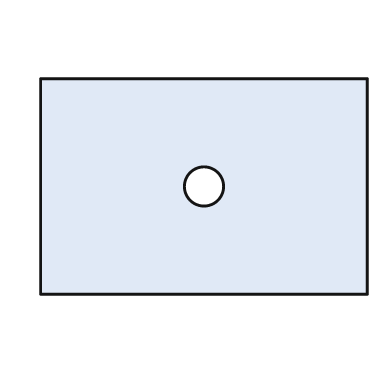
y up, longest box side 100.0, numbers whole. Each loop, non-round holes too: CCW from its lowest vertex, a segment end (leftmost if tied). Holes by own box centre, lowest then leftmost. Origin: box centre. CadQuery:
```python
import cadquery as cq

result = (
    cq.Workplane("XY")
    .moveTo(-50.0, -33.0)
    .lineTo(50.0, -33.0)
    .lineTo(50.0, 33.0)
    .lineTo(-50.0, 33.0)
    .close()
    .moveTo(0.0, 0.0)
    .circle(6.0)
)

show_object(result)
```